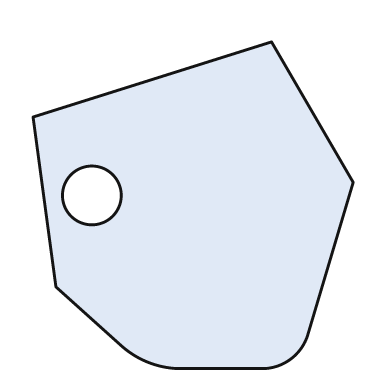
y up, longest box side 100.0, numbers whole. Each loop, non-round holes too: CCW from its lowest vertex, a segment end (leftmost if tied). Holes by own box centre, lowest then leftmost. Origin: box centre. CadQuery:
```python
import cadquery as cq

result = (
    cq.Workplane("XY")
    .moveTo(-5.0, -50.0)
    .lineTo(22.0, -50.0)
    .threePointArc((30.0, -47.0), (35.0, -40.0))
    .lineTo(49.0, 7.0)
    .lineTo(24.0, 50.0)
    .lineTo(-49.0, 27.0)
    .lineTo(-42.0, -25.0)
    .lineTo(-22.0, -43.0)
    .threePointArc((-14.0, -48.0), (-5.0, -50.0))
    .close()
    .moveTo(-31.0, 3.0)
    .circle(9.0)
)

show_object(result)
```